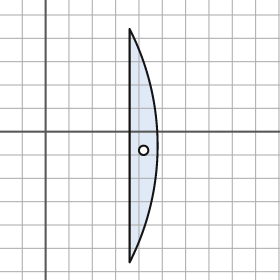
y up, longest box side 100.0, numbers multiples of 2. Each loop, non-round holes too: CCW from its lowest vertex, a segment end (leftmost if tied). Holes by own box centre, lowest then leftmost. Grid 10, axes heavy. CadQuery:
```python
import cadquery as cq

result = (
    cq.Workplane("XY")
    .moveTo(36.0, -56.0)
    .threePointArc((48.0, -6.0), (36.0, 44.0))
    .close()
    .moveTo(42.0, -8.0)
    .circle(2.0)
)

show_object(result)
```